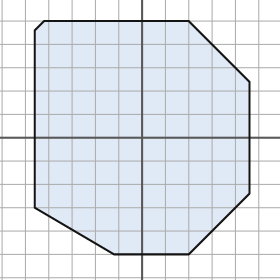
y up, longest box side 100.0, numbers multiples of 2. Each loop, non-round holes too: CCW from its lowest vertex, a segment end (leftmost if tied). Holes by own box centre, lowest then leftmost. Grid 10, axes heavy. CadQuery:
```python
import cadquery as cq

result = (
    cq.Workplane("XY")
    .moveTo(-12.0, -50.0)
    .lineTo(20.0, -50.0)
    .lineTo(46.0, -24.0)
    .lineTo(46.0, 24.0)
    .lineTo(20.0, 50.0)
    .lineTo(-42.0, 50.0)
    .lineTo(-46.0, 46.0)
    .lineTo(-46.0, -30.0)
    .close()
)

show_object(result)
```